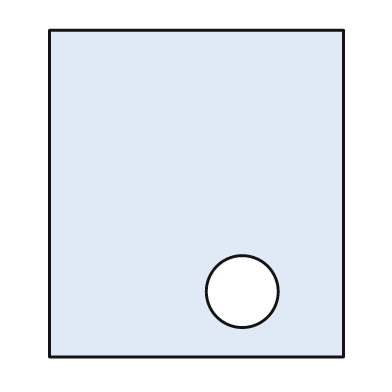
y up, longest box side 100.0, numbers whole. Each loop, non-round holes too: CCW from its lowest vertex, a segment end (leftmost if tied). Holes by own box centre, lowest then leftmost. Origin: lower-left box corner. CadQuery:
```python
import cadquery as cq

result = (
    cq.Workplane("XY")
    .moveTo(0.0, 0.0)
    .lineTo(90.0, 0.0)
    .lineTo(90.0, 100.0)
    .lineTo(0.0, 100.0)
    .close()
    .moveTo(59.0, 20.0)
    .circle(11.0)
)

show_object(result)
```